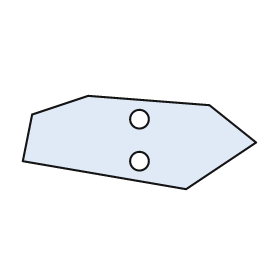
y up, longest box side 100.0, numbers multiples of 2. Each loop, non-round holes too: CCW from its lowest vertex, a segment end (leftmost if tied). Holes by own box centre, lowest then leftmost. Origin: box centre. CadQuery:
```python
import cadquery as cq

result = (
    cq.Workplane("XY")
    .moveTo(20.0, -20.0)
    .lineTo(50.0, 0.0)
    .lineTo(30.0, 16.0)
    .lineTo(-22.0, 20.0)
    .lineTo(-46.0, 12.0)
    .lineTo(-50.0, -8.0)
    .close()
    .moveTo(0.0, -8.0)
    .circle(4.0)
    .moveTo(0.0, 10.0)
    .circle(4.0)
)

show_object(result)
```